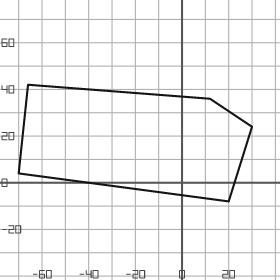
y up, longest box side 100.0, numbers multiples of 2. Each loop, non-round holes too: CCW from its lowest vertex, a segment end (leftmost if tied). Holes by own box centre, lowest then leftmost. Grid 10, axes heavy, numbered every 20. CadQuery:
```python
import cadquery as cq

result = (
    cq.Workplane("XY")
    .moveTo(20.0, -8.0)
    .lineTo(30.0, 24.0)
    .lineTo(12.0, 36.0)
    .lineTo(-66.0, 42.0)
    .lineTo(-70.0, 4.0)
    .close()
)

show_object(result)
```